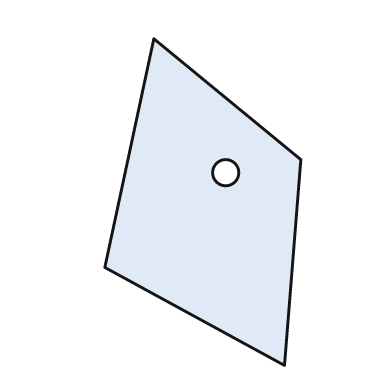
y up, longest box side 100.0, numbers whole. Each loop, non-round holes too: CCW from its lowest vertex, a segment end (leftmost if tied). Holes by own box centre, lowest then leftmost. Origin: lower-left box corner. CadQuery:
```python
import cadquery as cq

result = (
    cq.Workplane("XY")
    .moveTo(55.0, 0.0)
    .lineTo(60.0, 63.0)
    .lineTo(15.0, 100.0)
    .lineTo(0.0, 30.0)
    .close()
    .moveTo(37.0, 59.0)
    .circle(4.0)
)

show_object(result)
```